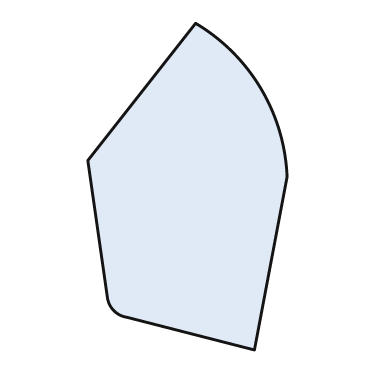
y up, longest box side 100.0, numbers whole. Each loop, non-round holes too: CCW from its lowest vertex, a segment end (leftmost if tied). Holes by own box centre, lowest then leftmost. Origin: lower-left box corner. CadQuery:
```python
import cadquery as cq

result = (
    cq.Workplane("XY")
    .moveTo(51.0, 0.0)
    .lineTo(61.0, 53.0)
    .threePointArc((53.0, 80.0), (33.0, 100.0))
    .lineTo(0.0, 58.0)
    .lineTo(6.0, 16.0)
    .threePointArc((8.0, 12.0), (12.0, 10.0))
    .close()
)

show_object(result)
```